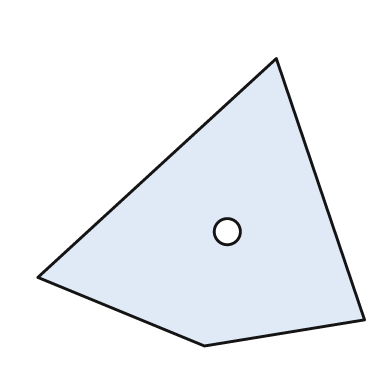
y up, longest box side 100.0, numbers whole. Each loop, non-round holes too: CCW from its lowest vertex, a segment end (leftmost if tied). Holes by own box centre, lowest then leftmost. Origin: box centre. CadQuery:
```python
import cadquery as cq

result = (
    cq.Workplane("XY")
    .moveTo(1.0, -44.0)
    .lineTo(50.0, -36.0)
    .lineTo(23.0, 44.0)
    .lineTo(-50.0, -23.0)
    .close()
    .moveTo(8.0, -9.0)
    .circle(4.0)
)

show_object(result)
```